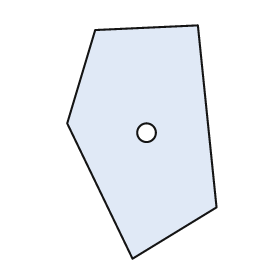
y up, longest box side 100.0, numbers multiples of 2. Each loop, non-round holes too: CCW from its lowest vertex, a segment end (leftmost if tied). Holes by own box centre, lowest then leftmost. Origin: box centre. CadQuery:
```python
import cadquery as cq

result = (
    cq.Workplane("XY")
    .moveTo(-4.0, -50.0)
    .lineTo(32.0, -28.0)
    .lineTo(24.0, 50.0)
    .lineTo(-20.0, 48.0)
    .lineTo(-32.0, 8.0)
    .close()
    .moveTo(2.0, 4.0)
    .circle(4.0)
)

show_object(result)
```